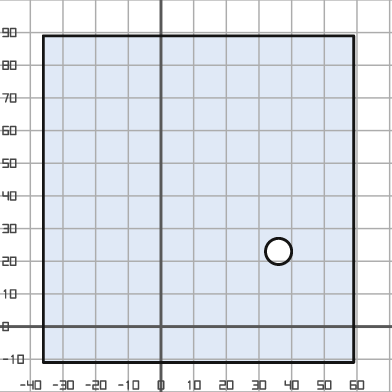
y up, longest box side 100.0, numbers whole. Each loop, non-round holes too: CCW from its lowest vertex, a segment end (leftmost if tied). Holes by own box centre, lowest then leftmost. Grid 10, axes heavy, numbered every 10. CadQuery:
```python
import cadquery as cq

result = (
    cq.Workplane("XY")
    .moveTo(-36.0, -11.0)
    .lineTo(59.0, -11.0)
    .lineTo(59.0, 89.0)
    .lineTo(-36.0, 89.0)
    .close()
    .moveTo(36.0, 23.0)
    .circle(4.0)
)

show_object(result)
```